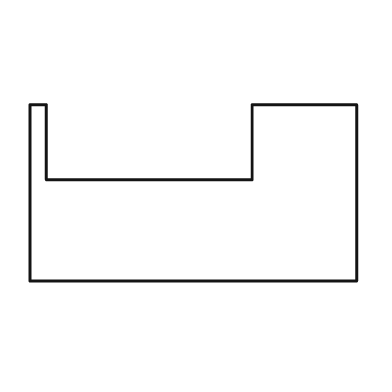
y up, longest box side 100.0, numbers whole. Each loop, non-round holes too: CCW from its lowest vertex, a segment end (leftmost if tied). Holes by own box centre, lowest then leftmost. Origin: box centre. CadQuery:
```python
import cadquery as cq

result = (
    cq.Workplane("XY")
    .moveTo(-50.0, -27.0)
    .lineTo(50.0, -27.0)
    .lineTo(50.0, 27.0)
    .lineTo(18.0, 27.0)
    .lineTo(18.0, 4.0)
    .lineTo(-45.0, 4.0)
    .lineTo(-45.0, 27.0)
    .lineTo(-50.0, 27.0)
    .close()
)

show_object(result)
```